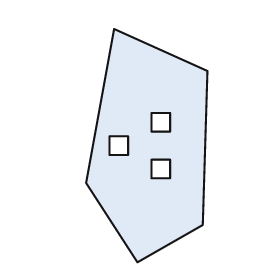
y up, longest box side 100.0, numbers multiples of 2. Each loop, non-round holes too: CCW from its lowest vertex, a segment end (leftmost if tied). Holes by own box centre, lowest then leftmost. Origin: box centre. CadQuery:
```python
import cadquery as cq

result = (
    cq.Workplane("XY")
    .moveTo(-4.0, -50.0)
    .lineTo(24.0, -34.0)
    .lineTo(26.0, 32.0)
    .lineTo(-14.0, 50.0)
    .lineTo(-26.0, -16.0)
    .close()
    .moveTo(2.0, -14.0)
    .lineTo(10.0, -14.0)
    .lineTo(10.0, -6.0)
    .lineTo(2.0, -6.0)
    .close()
    .moveTo(-16.0, -4.0)
    .lineTo(-8.0, -4.0)
    .lineTo(-8.0, 4.0)
    .lineTo(-16.0, 4.0)
    .close()
    .moveTo(2.0, 6.0)
    .lineTo(10.0, 6.0)
    .lineTo(10.0, 14.0)
    .lineTo(2.0, 14.0)
    .close()
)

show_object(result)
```